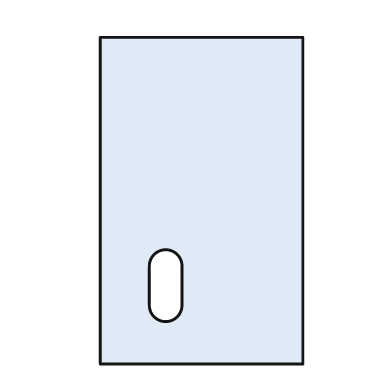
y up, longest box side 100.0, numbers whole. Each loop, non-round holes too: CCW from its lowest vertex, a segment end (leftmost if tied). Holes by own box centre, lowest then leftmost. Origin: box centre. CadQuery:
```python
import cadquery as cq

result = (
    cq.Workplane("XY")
    .moveTo(-31.0, -50.0)
    .lineTo(31.0, -50.0)
    .lineTo(31.0, 50.0)
    .lineTo(-31.0, 50.0)
    .close()
    .moveTo(-16.0, -32.0)
    .threePointArc((-11.0, -37.0), (-6.0, -32.0))
    .lineTo(-6.0, -20.0)
    .threePointArc((-11.0, -15.0), (-16.0, -20.0))
    .close()
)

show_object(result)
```